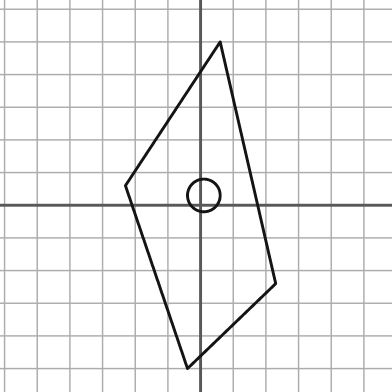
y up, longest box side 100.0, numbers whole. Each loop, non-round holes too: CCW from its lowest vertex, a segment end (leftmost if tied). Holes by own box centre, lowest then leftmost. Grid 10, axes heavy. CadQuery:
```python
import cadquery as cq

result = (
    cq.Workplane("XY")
    .moveTo(-4.0, -50.0)
    .lineTo(23.0, -24.0)
    .lineTo(6.0, 50.0)
    .lineTo(-23.0, 6.0)
    .close()
    .moveTo(1.0, 3.0)
    .circle(5.0)
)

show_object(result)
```